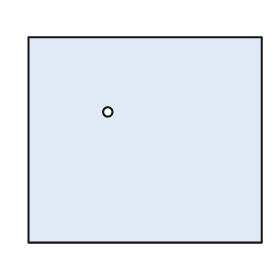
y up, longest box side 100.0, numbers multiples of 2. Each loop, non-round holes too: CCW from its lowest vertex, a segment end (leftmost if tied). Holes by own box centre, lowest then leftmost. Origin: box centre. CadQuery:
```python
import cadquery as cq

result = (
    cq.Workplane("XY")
    .moveTo(-50.0, -44.0)
    .lineTo(50.0, -44.0)
    .lineTo(50.0, 44.0)
    .lineTo(-50.0, 44.0)
    .close()
    .moveTo(-16.0, 12.0)
    .circle(2.0)
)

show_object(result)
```